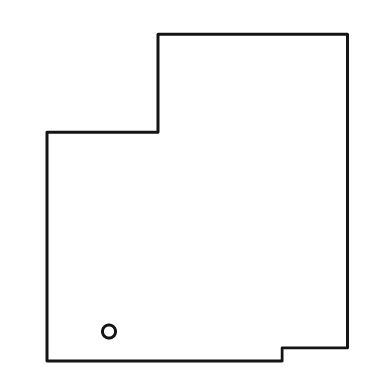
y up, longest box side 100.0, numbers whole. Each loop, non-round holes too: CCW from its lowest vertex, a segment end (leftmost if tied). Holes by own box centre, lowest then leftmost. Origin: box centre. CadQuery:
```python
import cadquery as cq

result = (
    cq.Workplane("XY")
    .moveTo(-46.0, -50.0)
    .lineTo(26.0, -50.0)
    .lineTo(26.0, -46.0)
    .lineTo(46.0, -46.0)
    .lineTo(46.0, 50.0)
    .lineTo(-12.0, 50.0)
    .lineTo(-12.0, 20.0)
    .lineTo(-46.0, 20.0)
    .close()
    .moveTo(-27.0, -41.0)
    .circle(2.0)
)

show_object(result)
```